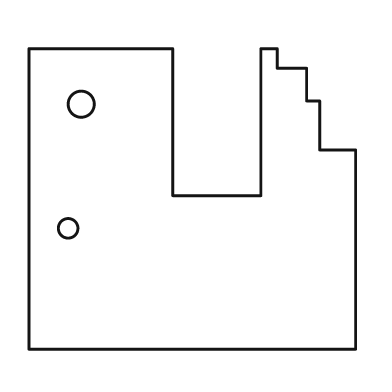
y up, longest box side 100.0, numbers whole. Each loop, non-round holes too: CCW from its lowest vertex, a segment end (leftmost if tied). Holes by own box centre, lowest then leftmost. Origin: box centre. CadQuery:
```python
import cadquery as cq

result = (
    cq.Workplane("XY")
    .moveTo(-50.0, -46.0)
    .lineTo(50.0, -46.0)
    .lineTo(50.0, 15.0)
    .lineTo(39.0, 15.0)
    .lineTo(39.0, 30.0)
    .lineTo(35.0, 30.0)
    .lineTo(35.0, 40.0)
    .lineTo(26.0, 40.0)
    .lineTo(26.0, 46.0)
    .lineTo(21.0, 46.0)
    .lineTo(21.0, 1.0)
    .lineTo(-6.0, 1.0)
    .lineTo(-6.0, 46.0)
    .lineTo(-50.0, 46.0)
    .close()
    .moveTo(-38.0, -9.0)
    .circle(3.0)
    .moveTo(-34.0, 29.0)
    .circle(4.0)
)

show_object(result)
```